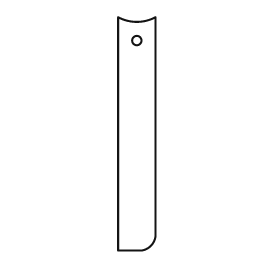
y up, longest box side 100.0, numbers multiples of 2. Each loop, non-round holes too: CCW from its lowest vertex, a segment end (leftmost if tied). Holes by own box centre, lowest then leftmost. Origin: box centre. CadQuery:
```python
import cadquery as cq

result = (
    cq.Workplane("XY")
    .moveTo(-8.0, -50.0)
    .lineTo(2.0, -50.0)
    .threePointArc((6.0, -48.0), (8.0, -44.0))
    .lineTo(8.0, 50.0)
    .threePointArc((0.0, 48.0), (-8.0, 50.0))
    .close()
    .moveTo(0.0, 40.0)
    .circle(2.0)
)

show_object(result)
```